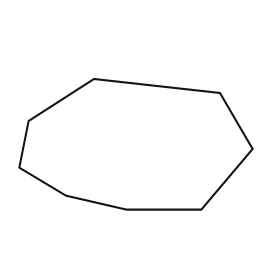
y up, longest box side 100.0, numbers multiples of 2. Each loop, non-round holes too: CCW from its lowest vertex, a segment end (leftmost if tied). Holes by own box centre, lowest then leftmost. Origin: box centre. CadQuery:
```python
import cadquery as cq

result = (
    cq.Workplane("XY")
    .moveTo(-4.0, -28.0)
    .lineTo(28.0, -28.0)
    .lineTo(50.0, -2.0)
    .lineTo(36.0, 22.0)
    .lineTo(-18.0, 28.0)
    .lineTo(-46.0, 10.0)
    .lineTo(-50.0, -10.0)
    .lineTo(-30.0, -22.0)
    .close()
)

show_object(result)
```